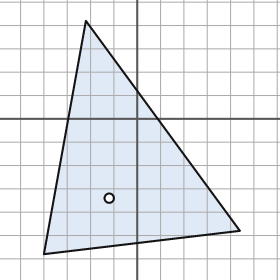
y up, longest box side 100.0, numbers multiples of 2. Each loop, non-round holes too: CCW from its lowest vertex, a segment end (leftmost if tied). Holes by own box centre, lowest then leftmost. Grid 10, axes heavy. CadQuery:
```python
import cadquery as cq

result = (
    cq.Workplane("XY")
    .moveTo(-40.0, -58.0)
    .lineTo(44.0, -48.0)
    .lineTo(-22.0, 42.0)
    .close()
    .moveTo(-12.0, -34.0)
    .circle(2.0)
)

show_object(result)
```